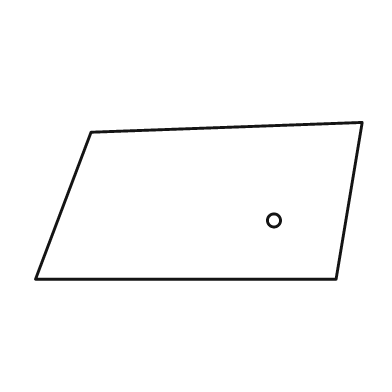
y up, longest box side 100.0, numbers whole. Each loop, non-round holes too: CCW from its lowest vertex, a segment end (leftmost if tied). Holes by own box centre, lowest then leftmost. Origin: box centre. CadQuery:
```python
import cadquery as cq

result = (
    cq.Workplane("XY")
    .moveTo(-50.0, -24.0)
    .lineTo(42.0, -24.0)
    .lineTo(50.0, 24.0)
    .lineTo(-33.0, 21.0)
    .close()
    .moveTo(23.0, -6.0)
    .circle(2.0)
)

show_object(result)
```